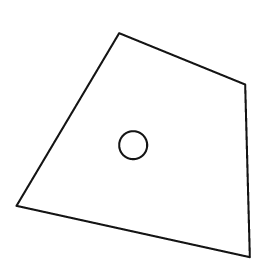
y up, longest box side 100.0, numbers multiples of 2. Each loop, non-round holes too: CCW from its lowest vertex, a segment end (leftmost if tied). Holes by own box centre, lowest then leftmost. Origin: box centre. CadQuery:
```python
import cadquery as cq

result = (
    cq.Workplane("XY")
    .moveTo(50.0, -48.0)
    .lineTo(48.0, 26.0)
    .lineTo(-6.0, 48.0)
    .lineTo(-50.0, -26.0)
    .close()
    .moveTo(0.0, 0.0)
    .circle(6.0)
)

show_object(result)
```